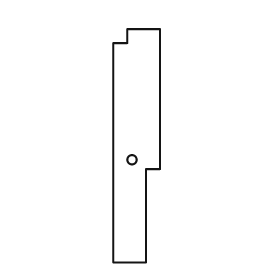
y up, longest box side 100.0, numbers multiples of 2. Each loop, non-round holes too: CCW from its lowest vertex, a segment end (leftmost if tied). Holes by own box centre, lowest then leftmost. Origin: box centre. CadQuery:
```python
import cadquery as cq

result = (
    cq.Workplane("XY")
    .moveTo(-10.0, -50.0)
    .lineTo(4.0, -50.0)
    .lineTo(4.0, -10.0)
    .lineTo(10.0, -10.0)
    .lineTo(10.0, 50.0)
    .lineTo(-4.0, 50.0)
    .lineTo(-4.0, 44.0)
    .lineTo(-10.0, 44.0)
    .close()
    .moveTo(-2.0, -6.0)
    .circle(2.0)
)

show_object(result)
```